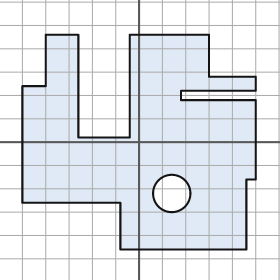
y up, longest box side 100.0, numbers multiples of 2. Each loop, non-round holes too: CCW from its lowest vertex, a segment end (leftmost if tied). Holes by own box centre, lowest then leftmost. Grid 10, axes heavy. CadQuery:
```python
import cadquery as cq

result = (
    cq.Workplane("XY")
    .moveTo(-8.0, -46.0)
    .lineTo(46.0, -46.0)
    .lineTo(46.0, -16.0)
    .lineTo(50.0, -16.0)
    .lineTo(50.0, 18.0)
    .lineTo(18.0, 18.0)
    .lineTo(18.0, 22.0)
    .lineTo(50.0, 22.0)
    .lineTo(50.0, 28.0)
    .lineTo(30.0, 28.0)
    .lineTo(30.0, 46.0)
    .lineTo(-4.0, 46.0)
    .lineTo(-4.0, 2.0)
    .lineTo(-26.0, 2.0)
    .lineTo(-26.0, 46.0)
    .lineTo(-40.0, 46.0)
    .lineTo(-40.0, 24.0)
    .lineTo(-50.0, 24.0)
    .lineTo(-50.0, -26.0)
    .lineTo(-8.0, -26.0)
    .close()
    .moveTo(14.0, -22.0)
    .circle(8.0)
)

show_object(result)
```